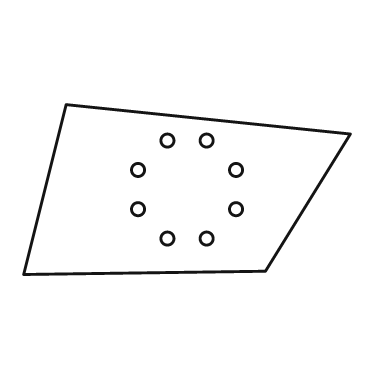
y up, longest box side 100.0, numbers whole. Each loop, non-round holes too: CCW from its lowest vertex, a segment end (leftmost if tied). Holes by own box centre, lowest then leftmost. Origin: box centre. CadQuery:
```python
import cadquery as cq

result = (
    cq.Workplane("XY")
    .moveTo(-50.0, -26.0)
    .lineTo(24.0, -25.0)
    .lineTo(50.0, 17.0)
    .lineTo(-37.0, 26.0)
    .close()
    .moveTo(-6.0, -15.0)
    .circle(2.0)
    .moveTo(6.0, -15.0)
    .circle(2.0)
    .moveTo(-15.0, -6.0)
    .circle(2.0)
    .moveTo(15.0, -6.0)
    .circle(2.0)
    .moveTo(-15.0, 6.0)
    .circle(2.0)
    .moveTo(15.0, 6.0)
    .circle(2.0)
    .moveTo(-6.0, 15.0)
    .circle(2.0)
    .moveTo(6.0, 15.0)
    .circle(2.0)
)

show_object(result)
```